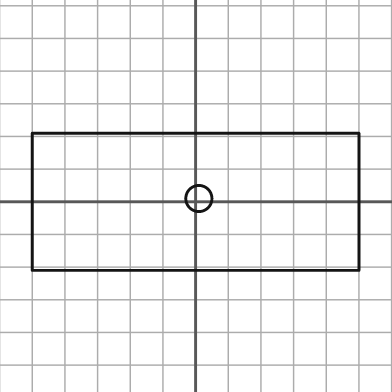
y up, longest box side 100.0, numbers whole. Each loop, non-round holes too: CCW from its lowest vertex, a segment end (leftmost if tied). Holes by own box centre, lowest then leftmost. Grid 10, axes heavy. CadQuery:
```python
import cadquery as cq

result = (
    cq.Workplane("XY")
    .moveTo(-50.0, -21.0)
    .lineTo(50.0, -21.0)
    .lineTo(50.0, 21.0)
    .lineTo(-50.0, 21.0)
    .close()
    .moveTo(1.0, 1.0)
    .circle(4.0)
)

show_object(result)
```